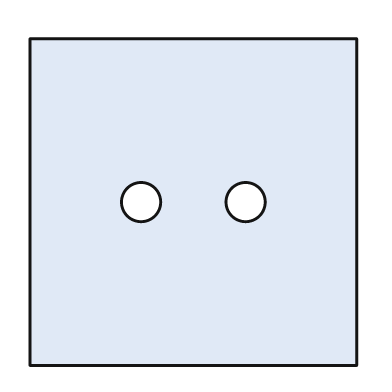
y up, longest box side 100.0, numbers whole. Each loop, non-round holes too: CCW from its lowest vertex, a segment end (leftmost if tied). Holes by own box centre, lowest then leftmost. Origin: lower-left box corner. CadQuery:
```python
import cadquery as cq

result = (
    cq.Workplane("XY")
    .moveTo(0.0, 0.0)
    .lineTo(100.0, 0.0)
    .lineTo(100.0, 100.0)
    .lineTo(0.0, 100.0)
    .close()
    .moveTo(34.0, 50.0)
    .circle(6.0)
    .moveTo(66.0, 50.0)
    .circle(6.0)
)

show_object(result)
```